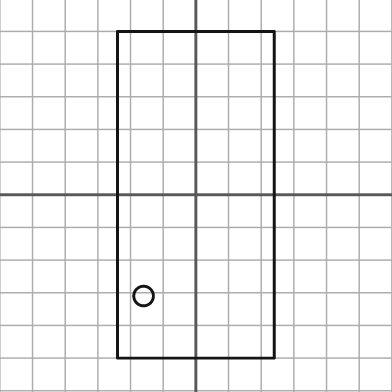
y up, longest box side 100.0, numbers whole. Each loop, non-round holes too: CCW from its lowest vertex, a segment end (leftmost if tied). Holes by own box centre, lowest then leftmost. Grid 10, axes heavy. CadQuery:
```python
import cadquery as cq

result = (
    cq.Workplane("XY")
    .moveTo(-24.0, -50.0)
    .lineTo(24.0, -50.0)
    .lineTo(24.0, 50.0)
    .lineTo(-24.0, 50.0)
    .close()
    .moveTo(-16.0, -31.0)
    .circle(3.0)
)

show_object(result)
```